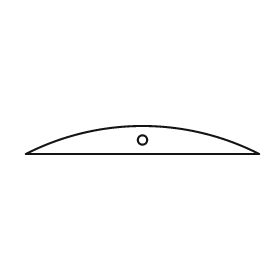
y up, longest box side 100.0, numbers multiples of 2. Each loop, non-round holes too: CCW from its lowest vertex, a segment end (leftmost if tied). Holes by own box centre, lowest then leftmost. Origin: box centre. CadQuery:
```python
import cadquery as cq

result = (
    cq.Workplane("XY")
    .moveTo(-50.0, -6.0)
    .lineTo(50.0, -6.0)
    .threePointArc((0.0, 6.0), (-50.0, -6.0))
    .close()
    .moveTo(0.0, 0.0)
    .circle(2.0)
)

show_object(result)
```